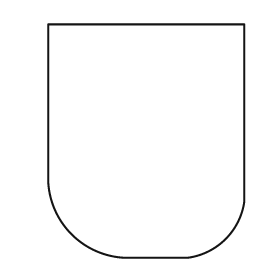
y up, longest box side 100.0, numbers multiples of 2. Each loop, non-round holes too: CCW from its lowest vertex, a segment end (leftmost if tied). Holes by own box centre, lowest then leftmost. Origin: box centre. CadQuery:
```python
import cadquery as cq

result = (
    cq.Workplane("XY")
    .moveTo(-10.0, -50.0)
    .lineTo(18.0, -50.0)
    .threePointArc((34.0, -42.0), (42.0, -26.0))
    .lineTo(42.0, 50.0)
    .lineTo(-42.0, 50.0)
    .lineTo(-42.0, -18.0)
    .threePointArc((-32.0, -40.0), (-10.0, -50.0))
    .close()
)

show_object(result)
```